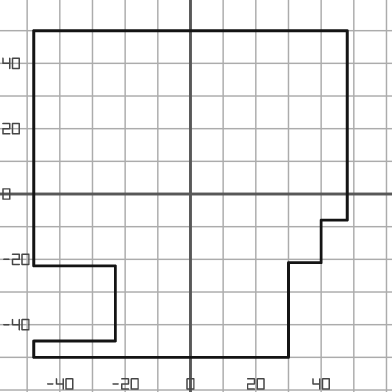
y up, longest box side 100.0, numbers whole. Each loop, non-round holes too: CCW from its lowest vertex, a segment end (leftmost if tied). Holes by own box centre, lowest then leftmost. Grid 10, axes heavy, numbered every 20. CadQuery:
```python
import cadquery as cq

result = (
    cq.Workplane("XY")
    .moveTo(-48.0, -50.0)
    .lineTo(30.0, -50.0)
    .lineTo(30.0, -21.0)
    .lineTo(40.0, -21.0)
    .lineTo(40.0, -8.0)
    .lineTo(48.0, -8.0)
    .lineTo(48.0, 50.0)
    .lineTo(-48.0, 50.0)
    .lineTo(-48.0, -22.0)
    .lineTo(-23.0, -22.0)
    .lineTo(-23.0, -45.0)
    .lineTo(-48.0, -45.0)
    .close()
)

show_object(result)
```